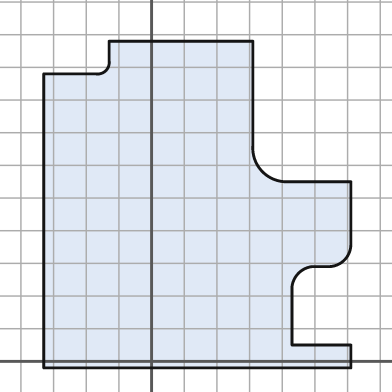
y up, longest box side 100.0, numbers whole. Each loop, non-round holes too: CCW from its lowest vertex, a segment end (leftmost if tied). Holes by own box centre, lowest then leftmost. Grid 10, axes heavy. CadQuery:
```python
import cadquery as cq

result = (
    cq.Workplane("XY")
    .moveTo(-33.0, -2.0)
    .lineTo(61.0, -2.0)
    .lineTo(61.0, 5.0)
    .lineTo(43.0, 5.0)
    .lineTo(43.0, 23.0)
    .threePointArc((45.0, 27.0), (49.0, 29.0))
    .lineTo(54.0, 29.0)
    .threePointArc((59.0, 31.0), (61.0, 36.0))
    .lineTo(61.0, 55.0)
    .lineTo(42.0, 55.0)
    .threePointArc((34.0, 58.0), (31.0, 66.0))
    .lineTo(31.0, 98.0)
    .lineTo(-13.0, 98.0)
    .lineTo(-13.0, 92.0)
    .threePointArc((-14.0, 89.0), (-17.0, 88.0))
    .lineTo(-33.0, 88.0)
    .close()
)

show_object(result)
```